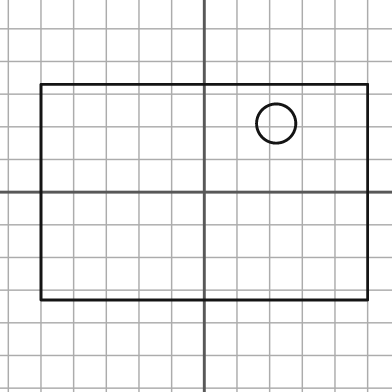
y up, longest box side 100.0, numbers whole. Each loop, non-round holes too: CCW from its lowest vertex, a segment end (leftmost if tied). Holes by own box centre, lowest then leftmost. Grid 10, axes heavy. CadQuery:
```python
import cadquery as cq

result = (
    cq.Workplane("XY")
    .moveTo(-50.0, -33.0)
    .lineTo(50.0, -33.0)
    .lineTo(50.0, 33.0)
    .lineTo(-50.0, 33.0)
    .close()
    .moveTo(22.0, 21.0)
    .circle(6.0)
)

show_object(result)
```